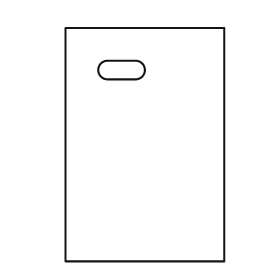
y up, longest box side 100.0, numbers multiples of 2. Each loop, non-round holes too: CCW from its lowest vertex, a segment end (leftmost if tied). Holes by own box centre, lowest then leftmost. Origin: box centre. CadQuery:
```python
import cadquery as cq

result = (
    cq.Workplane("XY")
    .moveTo(-34.0, -50.0)
    .lineTo(34.0, -50.0)
    .lineTo(34.0, 50.0)
    .lineTo(-34.0, 50.0)
    .close()
    .moveTo(-16.0, 28.0)
    .lineTo(-4.0, 28.0)
    .threePointArc((0.0, 32.0), (-4.0, 36.0))
    .lineTo(-16.0, 36.0)
    .threePointArc((-20.0, 32.0), (-16.0, 28.0))
    .close()
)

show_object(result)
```